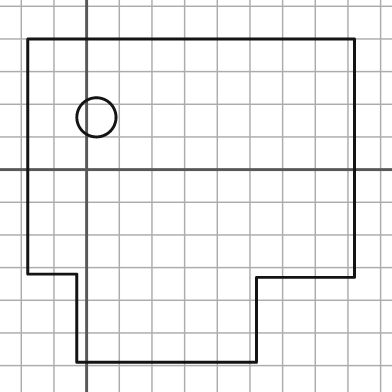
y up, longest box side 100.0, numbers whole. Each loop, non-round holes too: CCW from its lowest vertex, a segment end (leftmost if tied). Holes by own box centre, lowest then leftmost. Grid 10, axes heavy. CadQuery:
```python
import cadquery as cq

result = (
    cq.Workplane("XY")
    .moveTo(-3.0, -59.0)
    .lineTo(52.0, -59.0)
    .lineTo(52.0, -33.0)
    .lineTo(82.0, -33.0)
    .lineTo(82.0, 40.0)
    .lineTo(-18.0, 40.0)
    .lineTo(-18.0, -32.0)
    .lineTo(-3.0, -32.0)
    .close()
    .moveTo(3.0, 16.0)
    .circle(6.0)
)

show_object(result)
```